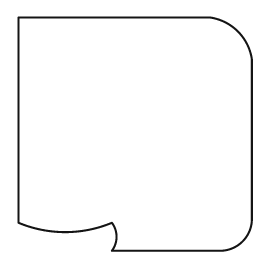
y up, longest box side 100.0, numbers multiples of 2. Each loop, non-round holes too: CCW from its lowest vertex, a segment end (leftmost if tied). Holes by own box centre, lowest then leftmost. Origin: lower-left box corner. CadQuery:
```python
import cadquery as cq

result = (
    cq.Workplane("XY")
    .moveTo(40.0, 0.0)
    .lineTo(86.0, 0.0)
    .threePointArc((96.0, 4.0), (100.0, 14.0))
    .lineTo(100.0, 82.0)
    .threePointArc((94.0, 94.0), (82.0, 100.0))
    .lineTo(0.0, 100.0)
    .lineTo(0.0, 12.0)
    .threePointArc((20.0, 8.0), (40.0, 12.0))
    .threePointArc((42.0, 6.0), (40.0, 0.0))
    .close()
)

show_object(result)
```